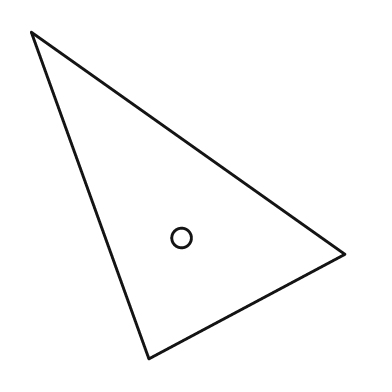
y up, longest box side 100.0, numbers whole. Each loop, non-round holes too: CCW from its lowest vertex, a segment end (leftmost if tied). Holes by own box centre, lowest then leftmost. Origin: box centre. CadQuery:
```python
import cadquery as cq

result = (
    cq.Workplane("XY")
    .moveTo(-12.0, -50.0)
    .lineTo(48.0, -18.0)
    .lineTo(-48.0, 50.0)
    .close()
    .moveTo(-2.0, -13.0)
    .circle(3.0)
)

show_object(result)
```